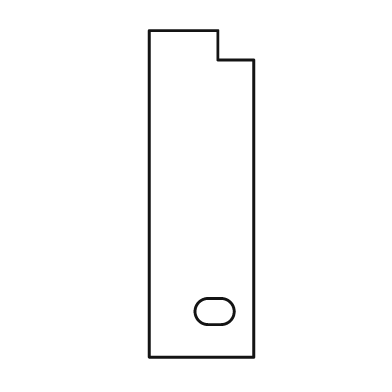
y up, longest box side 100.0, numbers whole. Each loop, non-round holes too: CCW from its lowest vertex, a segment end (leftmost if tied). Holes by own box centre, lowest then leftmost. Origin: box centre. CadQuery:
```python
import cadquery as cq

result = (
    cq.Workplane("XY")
    .moveTo(-16.0, -50.0)
    .lineTo(16.0, -50.0)
    .lineTo(16.0, 41.0)
    .lineTo(5.0, 41.0)
    .lineTo(5.0, 50.0)
    .lineTo(-16.0, 50.0)
    .close()
    .moveTo(2.0, -40.0)
    .lineTo(6.0, -40.0)
    .threePointArc((10.0, -36.0), (6.0, -32.0))
    .lineTo(2.0, -32.0)
    .threePointArc((-2.0, -36.0), (2.0, -40.0))
    .close()
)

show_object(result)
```